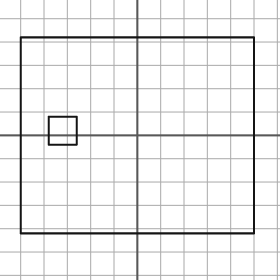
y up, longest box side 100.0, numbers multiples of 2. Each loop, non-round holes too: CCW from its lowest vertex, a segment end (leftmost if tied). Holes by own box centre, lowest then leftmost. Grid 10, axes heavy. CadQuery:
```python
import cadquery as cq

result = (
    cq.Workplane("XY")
    .moveTo(-50.0, -42.0)
    .lineTo(50.0, -42.0)
    .lineTo(50.0, 42.0)
    .lineTo(-50.0, 42.0)
    .close()
    .moveTo(-38.0, -4.0)
    .lineTo(-26.0, -4.0)
    .lineTo(-26.0, 8.0)
    .lineTo(-38.0, 8.0)
    .close()
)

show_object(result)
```